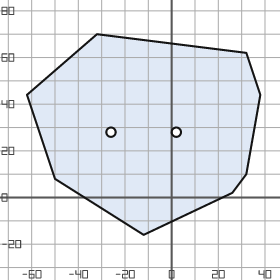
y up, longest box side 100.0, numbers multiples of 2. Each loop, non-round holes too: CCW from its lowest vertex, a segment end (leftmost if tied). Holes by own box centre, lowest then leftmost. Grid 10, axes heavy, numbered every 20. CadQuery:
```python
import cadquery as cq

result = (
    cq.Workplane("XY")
    .moveTo(-12.0, -16.0)
    .lineTo(26.0, 2.0)
    .lineTo(32.0, 10.0)
    .lineTo(38.0, 44.0)
    .lineTo(32.0, 62.0)
    .lineTo(-32.0, 70.0)
    .lineTo(-62.0, 44.0)
    .lineTo(-50.0, 8.0)
    .close()
    .moveTo(-26.0, 28.0)
    .circle(2.0)
    .moveTo(2.0, 28.0)
    .circle(2.0)
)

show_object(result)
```